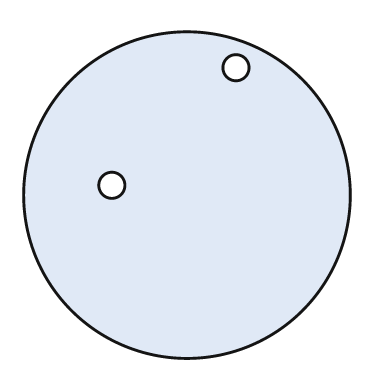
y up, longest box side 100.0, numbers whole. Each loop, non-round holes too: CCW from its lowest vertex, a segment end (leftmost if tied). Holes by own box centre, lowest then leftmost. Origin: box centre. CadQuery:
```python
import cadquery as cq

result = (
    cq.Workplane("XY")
    .moveTo(0.0, 0.0)
    .circle(50.0)
    .moveTo(-23.0, 3.0)
    .circle(4.0)
    .moveTo(15.0, 39.0)
    .circle(4.0)
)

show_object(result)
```